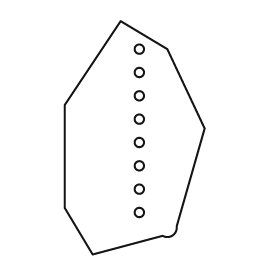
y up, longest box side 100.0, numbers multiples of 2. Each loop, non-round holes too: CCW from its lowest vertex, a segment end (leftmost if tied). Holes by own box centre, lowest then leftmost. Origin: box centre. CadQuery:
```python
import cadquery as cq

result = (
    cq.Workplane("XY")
    .moveTo(-18.0, -50.0)
    .lineTo(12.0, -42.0)
    .threePointArc((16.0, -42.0), (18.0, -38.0))
    .lineTo(30.0, 4.0)
    .lineTo(14.0, 38.0)
    .lineTo(-6.0, 50.0)
    .lineTo(-30.0, 14.0)
    .lineTo(-30.0, -30.0)
    .close()
    .moveTo(2.0, -32.0)
    .circle(2.0)
    .moveTo(2.0, -22.0)
    .circle(2.0)
    .moveTo(2.0, -12.0)
    .circle(2.0)
    .moveTo(2.0, -2.0)
    .circle(2.0)
    .moveTo(2.0, 8.0)
    .circle(2.0)
    .moveTo(2.0, 18.0)
    .circle(2.0)
    .moveTo(2.0, 28.0)
    .circle(2.0)
    .moveTo(2.0, 38.0)
    .circle(2.0)
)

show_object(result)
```